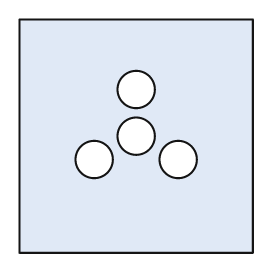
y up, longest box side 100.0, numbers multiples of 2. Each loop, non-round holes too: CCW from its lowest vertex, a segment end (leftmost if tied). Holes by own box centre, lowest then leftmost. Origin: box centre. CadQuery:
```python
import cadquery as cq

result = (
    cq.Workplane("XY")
    .moveTo(-50.0, -50.0)
    .lineTo(50.0, -50.0)
    .lineTo(50.0, 50.0)
    .lineTo(-50.0, 50.0)
    .close()
    .moveTo(-18.0, -10.0)
    .circle(8.0)
    .moveTo(18.0, -10.0)
    .circle(8.0)
    .moveTo(0.0, 0.0)
    .circle(8.0)
    .moveTo(0.0, 20.0)
    .circle(8.0)
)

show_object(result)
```